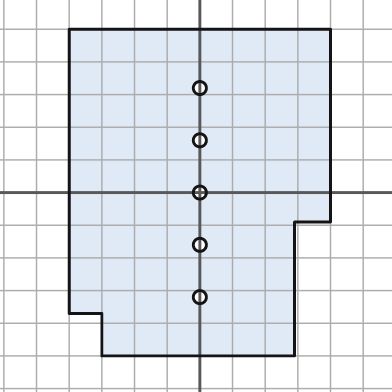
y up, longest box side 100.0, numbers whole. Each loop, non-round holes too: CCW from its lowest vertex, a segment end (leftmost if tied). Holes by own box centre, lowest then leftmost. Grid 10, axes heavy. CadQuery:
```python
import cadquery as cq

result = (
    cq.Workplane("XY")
    .moveTo(-30.0, -50.0)
    .lineTo(29.0, -50.0)
    .lineTo(29.0, -9.0)
    .lineTo(40.0, -9.0)
    .lineTo(40.0, 50.0)
    .lineTo(-40.0, 50.0)
    .lineTo(-40.0, -37.0)
    .lineTo(-30.0, -37.0)
    .close()
    .moveTo(0.0, -32.0)
    .circle(2.0)
    .moveTo(0.0, -16.0)
    .circle(2.0)
    .moveTo(0.0, 0.0)
    .circle(2.0)
    .moveTo(0.0, 16.0)
    .circle(2.0)
    .moveTo(0.0, 32.0)
    .circle(2.0)
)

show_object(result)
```